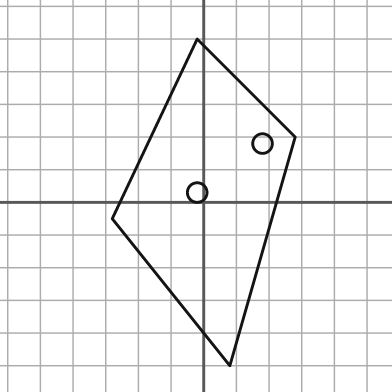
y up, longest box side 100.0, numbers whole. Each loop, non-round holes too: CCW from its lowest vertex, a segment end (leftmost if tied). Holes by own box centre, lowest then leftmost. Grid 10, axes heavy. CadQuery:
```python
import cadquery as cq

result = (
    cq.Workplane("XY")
    .moveTo(8.0, -50.0)
    .lineTo(28.0, 20.0)
    .lineTo(-2.0, 50.0)
    .lineTo(-28.0, -5.0)
    .close()
    .moveTo(-2.0, 3.0)
    .circle(3.0)
    .moveTo(18.0, 18.0)
    .circle(3.0)
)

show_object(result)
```